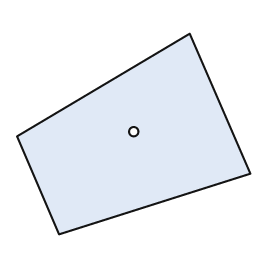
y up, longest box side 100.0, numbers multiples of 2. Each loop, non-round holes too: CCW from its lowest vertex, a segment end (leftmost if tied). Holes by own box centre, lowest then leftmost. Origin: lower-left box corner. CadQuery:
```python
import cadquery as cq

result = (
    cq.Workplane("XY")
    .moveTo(18.0, 0.0)
    .lineTo(100.0, 26.0)
    .lineTo(74.0, 86.0)
    .lineTo(0.0, 42.0)
    .close()
    .moveTo(50.0, 44.0)
    .circle(2.0)
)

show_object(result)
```